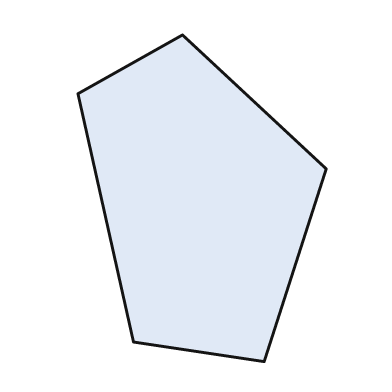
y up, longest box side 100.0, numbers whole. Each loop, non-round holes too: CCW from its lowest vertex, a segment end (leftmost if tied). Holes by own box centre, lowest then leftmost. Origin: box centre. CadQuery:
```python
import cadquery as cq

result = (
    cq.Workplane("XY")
    .moveTo(19.0, -50.0)
    .lineTo(38.0, 9.0)
    .lineTo(-6.0, 50.0)
    .lineTo(-38.0, 32.0)
    .lineTo(-21.0, -44.0)
    .close()
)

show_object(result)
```